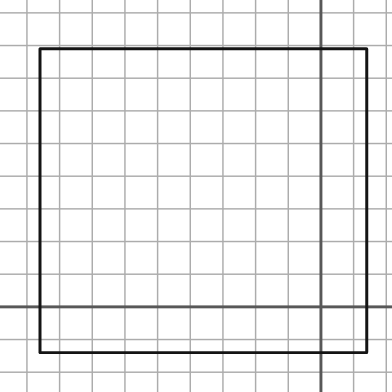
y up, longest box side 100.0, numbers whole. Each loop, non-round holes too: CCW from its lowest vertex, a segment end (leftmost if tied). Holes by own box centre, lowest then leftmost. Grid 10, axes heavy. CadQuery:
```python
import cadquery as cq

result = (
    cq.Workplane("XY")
    .moveTo(-86.0, -14.0)
    .lineTo(14.0, -14.0)
    .lineTo(14.0, 79.0)
    .lineTo(-86.0, 79.0)
    .close()
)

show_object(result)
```